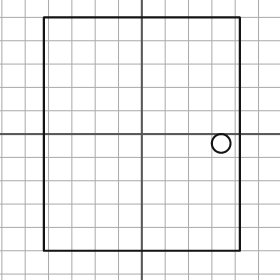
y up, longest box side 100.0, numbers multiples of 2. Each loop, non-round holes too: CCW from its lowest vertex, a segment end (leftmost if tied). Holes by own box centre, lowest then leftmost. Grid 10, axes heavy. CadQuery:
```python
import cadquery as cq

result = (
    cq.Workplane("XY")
    .moveTo(-42.0, -50.0)
    .lineTo(42.0, -50.0)
    .lineTo(42.0, 50.0)
    .lineTo(-42.0, 50.0)
    .close()
    .moveTo(34.0, -4.0)
    .circle(4.0)
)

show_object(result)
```